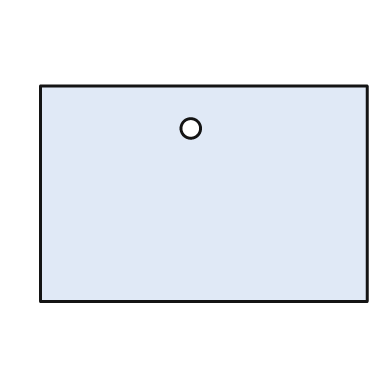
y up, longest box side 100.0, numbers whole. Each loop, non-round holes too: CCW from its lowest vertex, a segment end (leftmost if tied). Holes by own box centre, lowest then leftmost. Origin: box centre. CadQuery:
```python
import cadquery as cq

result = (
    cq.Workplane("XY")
    .moveTo(-50.0, -33.0)
    .lineTo(50.0, -33.0)
    .lineTo(50.0, 33.0)
    .lineTo(-50.0, 33.0)
    .close()
    .moveTo(-4.0, 20.0)
    .circle(3.0)
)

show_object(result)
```